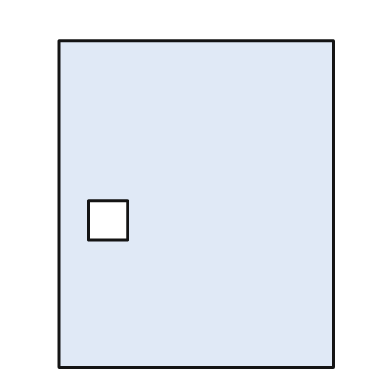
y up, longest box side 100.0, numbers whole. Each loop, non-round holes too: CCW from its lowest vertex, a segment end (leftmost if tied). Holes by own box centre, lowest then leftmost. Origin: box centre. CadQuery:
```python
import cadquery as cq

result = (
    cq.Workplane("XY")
    .moveTo(-42.0, -50.0)
    .lineTo(42.0, -50.0)
    .lineTo(42.0, 50.0)
    .lineTo(-42.0, 50.0)
    .close()
    .moveTo(-33.0, -11.0)
    .lineTo(-21.0, -11.0)
    .lineTo(-21.0, 1.0)
    .lineTo(-33.0, 1.0)
    .close()
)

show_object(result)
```